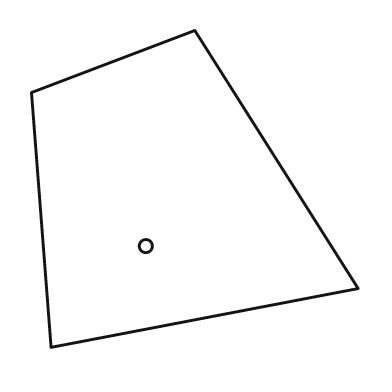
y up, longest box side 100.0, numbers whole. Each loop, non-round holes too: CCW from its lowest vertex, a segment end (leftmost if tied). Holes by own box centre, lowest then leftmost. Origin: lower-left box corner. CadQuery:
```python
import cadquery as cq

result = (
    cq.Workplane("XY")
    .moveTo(6.0, 0.0)
    .lineTo(100.0, 18.0)
    .lineTo(50.0, 97.0)
    .lineTo(0.0, 78.0)
    .close()
    .moveTo(35.0, 31.0)
    .circle(2.0)
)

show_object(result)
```